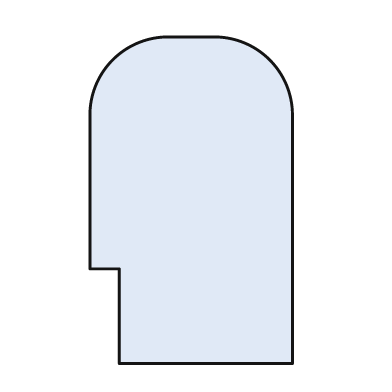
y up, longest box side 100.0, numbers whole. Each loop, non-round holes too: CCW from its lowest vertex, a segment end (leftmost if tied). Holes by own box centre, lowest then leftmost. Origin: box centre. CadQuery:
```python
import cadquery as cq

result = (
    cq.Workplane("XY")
    .moveTo(-22.0, -50.0)
    .lineTo(31.0, -50.0)
    .lineTo(31.0, 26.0)
    .threePointArc((24.0, 43.0), (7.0, 50.0))
    .lineTo(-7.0, 50.0)
    .threePointArc((-24.0, 43.0), (-31.0, 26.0))
    .lineTo(-31.0, -21.0)
    .lineTo(-22.0, -21.0)
    .close()
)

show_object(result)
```